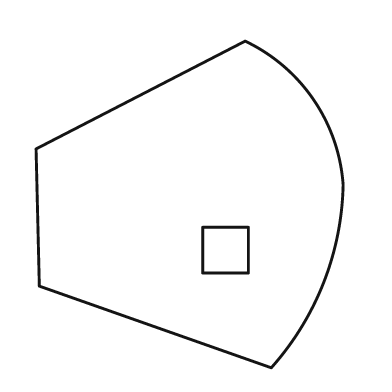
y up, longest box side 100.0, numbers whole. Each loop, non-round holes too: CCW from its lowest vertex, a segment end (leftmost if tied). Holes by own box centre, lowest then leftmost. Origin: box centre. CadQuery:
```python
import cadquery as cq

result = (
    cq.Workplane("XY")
    .moveTo(25.0, -50.0)
    .threePointArc((41.0, -24.0), (47.0, 6.0))
    .threePointArc((38.0, 32.0), (17.0, 50.0))
    .lineTo(-47.0, 17.0)
    .lineTo(-46.0, -25.0)
    .close()
    .moveTo(4.0, -21.0)
    .lineTo(18.0, -21.0)
    .lineTo(18.0, -7.0)
    .lineTo(4.0, -7.0)
    .close()
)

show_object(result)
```